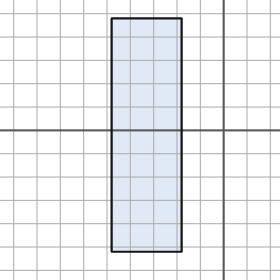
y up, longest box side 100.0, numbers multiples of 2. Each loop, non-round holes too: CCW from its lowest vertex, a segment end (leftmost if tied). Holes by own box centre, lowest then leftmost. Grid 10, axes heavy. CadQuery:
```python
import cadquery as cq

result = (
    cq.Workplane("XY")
    .moveTo(-48.0, -52.0)
    .lineTo(-18.0, -52.0)
    .lineTo(-18.0, 48.0)
    .lineTo(-48.0, 48.0)
    .close()
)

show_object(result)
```